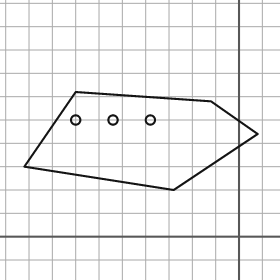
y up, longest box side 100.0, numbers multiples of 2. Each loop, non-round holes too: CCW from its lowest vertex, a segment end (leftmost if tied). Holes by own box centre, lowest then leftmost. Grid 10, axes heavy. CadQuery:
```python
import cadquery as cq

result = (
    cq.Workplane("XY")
    .moveTo(-28.0, 20.0)
    .lineTo(8.0, 44.0)
    .lineTo(-12.0, 58.0)
    .lineTo(-70.0, 62.0)
    .lineTo(-92.0, 30.0)
    .close()
    .moveTo(-70.0, 50.0)
    .circle(2.0)
    .moveTo(-54.0, 50.0)
    .circle(2.0)
    .moveTo(-38.0, 50.0)
    .circle(2.0)
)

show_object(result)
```